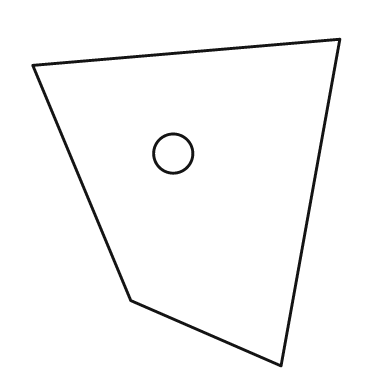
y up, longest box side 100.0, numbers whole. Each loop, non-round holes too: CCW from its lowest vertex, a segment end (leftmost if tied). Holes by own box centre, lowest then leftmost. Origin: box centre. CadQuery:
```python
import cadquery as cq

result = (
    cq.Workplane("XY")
    .moveTo(29.0, -50.0)
    .lineTo(47.0, 50.0)
    .lineTo(-47.0, 42.0)
    .lineTo(-17.0, -30.0)
    .close()
    .moveTo(-4.0, 15.0)
    .circle(6.0)
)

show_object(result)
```